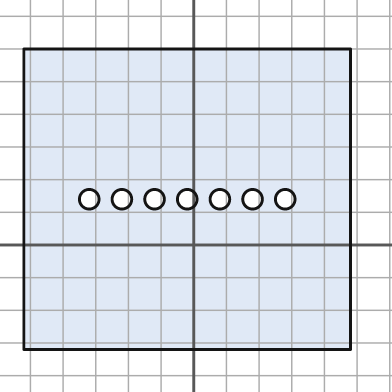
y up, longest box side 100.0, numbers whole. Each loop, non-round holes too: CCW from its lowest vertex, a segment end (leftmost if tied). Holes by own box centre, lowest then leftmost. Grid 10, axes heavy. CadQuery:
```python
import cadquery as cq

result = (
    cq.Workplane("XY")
    .moveTo(-52.0, -32.0)
    .lineTo(48.0, -32.0)
    .lineTo(48.0, 60.0)
    .lineTo(-52.0, 60.0)
    .close()
    .moveTo(-32.0, 14.0)
    .circle(3.0)
    .moveTo(-22.0, 14.0)
    .circle(3.0)
    .moveTo(-12.0, 14.0)
    .circle(3.0)
    .moveTo(-2.0, 14.0)
    .circle(3.0)
    .moveTo(8.0, 14.0)
    .circle(3.0)
    .moveTo(18.0, 14.0)
    .circle(3.0)
    .moveTo(28.0, 14.0)
    .circle(3.0)
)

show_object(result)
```